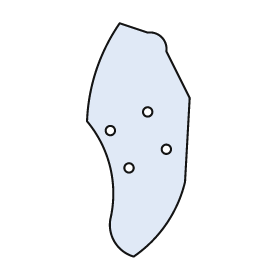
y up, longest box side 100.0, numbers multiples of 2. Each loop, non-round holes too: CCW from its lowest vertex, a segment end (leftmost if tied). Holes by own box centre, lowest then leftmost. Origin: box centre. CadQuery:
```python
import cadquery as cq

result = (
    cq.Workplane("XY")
    .moveTo(-2.0, -50.0)
    .threePointArc((12.0, -36.0), (20.0, -18.0))
    .lineTo(22.0, 18.0)
    .lineTo(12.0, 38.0)
    .threePointArc((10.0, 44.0), (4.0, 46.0))
    .lineTo(-8.0, 50.0)
    .threePointArc((-18.0, 30.0), (-22.0, 8.0))
    .threePointArc((-12.0, -12.0), (-12.0, -34.0))
    .threePointArc((-10.0, -44.0), (-2.0, -50.0))
    .close()
    .moveTo(-4.0, -12.0)
    .circle(2.0)
    .moveTo(12.0, -4.0)
    .circle(2.0)
    .moveTo(-12.0, 4.0)
    .circle(2.0)
    .moveTo(4.0, 12.0)
    .circle(2.0)
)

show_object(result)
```